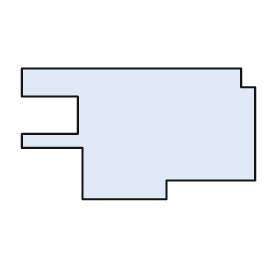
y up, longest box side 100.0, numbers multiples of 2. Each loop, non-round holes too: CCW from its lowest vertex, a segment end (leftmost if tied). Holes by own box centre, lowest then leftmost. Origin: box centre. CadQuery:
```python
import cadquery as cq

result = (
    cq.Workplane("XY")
    .moveTo(-24.0, -28.0)
    .lineTo(12.0, -28.0)
    .lineTo(12.0, -20.0)
    .lineTo(50.0, -20.0)
    .lineTo(50.0, 20.0)
    .lineTo(44.0, 20.0)
    .lineTo(44.0, 28.0)
    .lineTo(-50.0, 28.0)
    .lineTo(-50.0, 16.0)
    .lineTo(-26.0, 16.0)
    .lineTo(-26.0, 0.0)
    .lineTo(-50.0, 0.0)
    .lineTo(-50.0, -6.0)
    .lineTo(-24.0, -6.0)
    .close()
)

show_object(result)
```